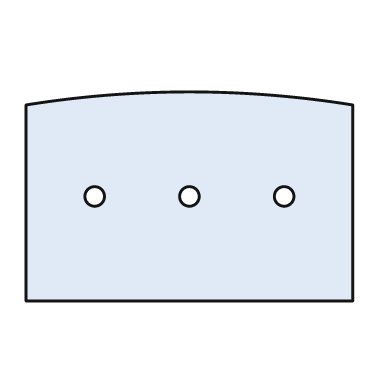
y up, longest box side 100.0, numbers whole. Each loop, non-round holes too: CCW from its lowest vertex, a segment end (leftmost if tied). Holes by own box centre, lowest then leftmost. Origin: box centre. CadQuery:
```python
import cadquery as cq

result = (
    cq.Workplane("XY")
    .moveTo(-50.0, -32.0)
    .lineTo(50.0, -32.0)
    .lineTo(50.0, 28.0)
    .threePointArc((0.0, 32.0), (-50.0, 28.0))
    .close()
    .moveTo(-29.0, 0.0)
    .circle(3.0)
    .moveTo(0.0, 0.0)
    .circle(3.0)
    .moveTo(29.0, 0.0)
    .circle(3.0)
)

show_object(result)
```